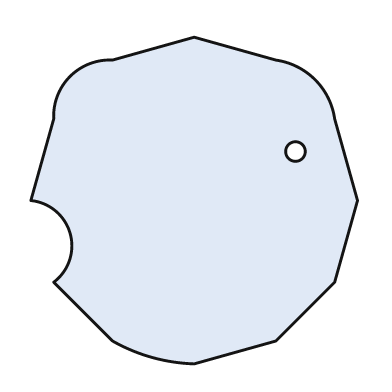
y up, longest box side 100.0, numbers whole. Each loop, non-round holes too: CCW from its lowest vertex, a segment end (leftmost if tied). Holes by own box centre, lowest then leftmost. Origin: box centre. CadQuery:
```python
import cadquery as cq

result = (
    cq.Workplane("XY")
    .moveTo(0.0, -50.0)
    .lineTo(25.0, -43.0)
    .lineTo(43.0, -25.0)
    .lineTo(50.0, 0.0)
    .lineTo(43.0, 25.0)
    .threePointArc((37.0, 37.0), (25.0, 43.0))
    .lineTo(0.0, 50.0)
    .lineTo(-25.0, 43.0)
    .threePointArc((-38.0, 38.0), (-43.0, 25.0))
    .lineTo(-50.0, 0.0)
    .threePointArc((-38.0, -10.0), (-43.0, -25.0))
    .lineTo(-25.0, -43.0)
    .threePointArc((-13.0, -48.0), (0.0, -50.0))
    .close()
    .moveTo(31.0, 15.0)
    .circle(3.0)
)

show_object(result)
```